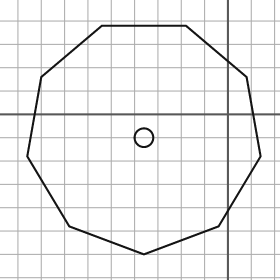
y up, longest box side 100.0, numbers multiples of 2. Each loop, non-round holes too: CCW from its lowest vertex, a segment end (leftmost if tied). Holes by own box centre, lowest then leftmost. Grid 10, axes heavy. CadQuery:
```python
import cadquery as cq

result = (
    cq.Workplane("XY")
    .moveTo(-36.0, -60.0)
    .lineTo(-4.0, -48.0)
    .lineTo(14.0, -18.0)
    .lineTo(8.0, 16.0)
    .lineTo(-18.0, 38.0)
    .lineTo(-54.0, 38.0)
    .lineTo(-80.0, 16.0)
    .lineTo(-86.0, -18.0)
    .lineTo(-68.0, -48.0)
    .close()
    .moveTo(-36.0, -10.0)
    .circle(4.0)
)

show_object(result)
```